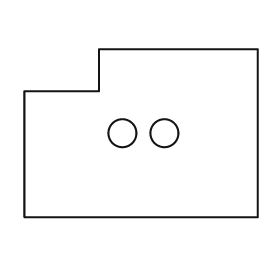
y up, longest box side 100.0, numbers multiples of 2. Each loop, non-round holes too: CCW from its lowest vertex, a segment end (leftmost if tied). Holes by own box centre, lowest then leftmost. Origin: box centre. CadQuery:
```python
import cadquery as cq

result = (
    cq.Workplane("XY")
    .moveTo(-50.0, -36.0)
    .lineTo(50.0, -36.0)
    .lineTo(50.0, 36.0)
    .lineTo(-18.0, 36.0)
    .lineTo(-18.0, 18.0)
    .lineTo(-50.0, 18.0)
    .close()
    .moveTo(-8.0, 0.0)
    .circle(6.0)
    .moveTo(10.0, 0.0)
    .circle(6.0)
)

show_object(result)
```